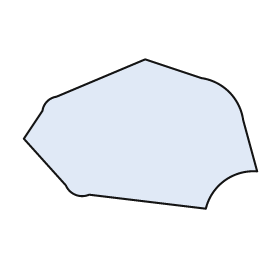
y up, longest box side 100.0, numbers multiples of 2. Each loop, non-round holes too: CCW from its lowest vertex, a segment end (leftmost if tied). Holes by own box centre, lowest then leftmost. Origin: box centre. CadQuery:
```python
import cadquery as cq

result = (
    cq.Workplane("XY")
    .moveTo(28.0, -32.0)
    .threePointArc((36.0, -20.0), (50.0, -16.0))
    .lineTo(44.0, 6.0)
    .threePointArc((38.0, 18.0), (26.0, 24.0))
    .lineTo(2.0, 32.0)
    .lineTo(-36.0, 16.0)
    .threePointArc((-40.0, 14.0), (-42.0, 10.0))
    .lineTo(-50.0, -2.0)
    .lineTo(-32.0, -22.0)
    .threePointArc((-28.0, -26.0), (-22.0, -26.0))
    .close()
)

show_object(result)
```